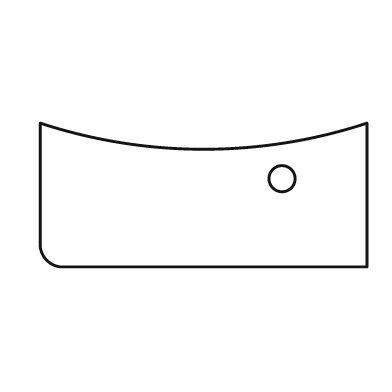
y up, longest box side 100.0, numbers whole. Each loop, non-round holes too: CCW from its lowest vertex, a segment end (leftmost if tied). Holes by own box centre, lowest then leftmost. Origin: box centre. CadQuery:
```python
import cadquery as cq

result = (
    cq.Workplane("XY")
    .moveTo(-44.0, -22.0)
    .lineTo(50.0, -22.0)
    .lineTo(50.0, 22.0)
    .threePointArc((0.0, 14.0), (-50.0, 22.0))
    .lineTo(-50.0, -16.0)
    .threePointArc((-48.0, -20.0), (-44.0, -22.0))
    .close()
    .moveTo(24.0, 5.0)
    .circle(4.0)
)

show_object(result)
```